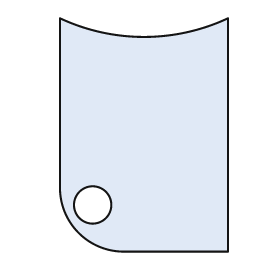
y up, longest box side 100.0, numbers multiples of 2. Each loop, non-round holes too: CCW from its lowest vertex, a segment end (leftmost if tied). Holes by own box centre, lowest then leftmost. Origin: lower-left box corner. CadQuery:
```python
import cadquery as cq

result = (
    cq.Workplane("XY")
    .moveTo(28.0, 0.0)
    .lineTo(72.0, 0.0)
    .lineTo(72.0, 100.0)
    .threePointArc((36.0, 92.0), (0.0, 100.0))
    .lineTo(0.0, 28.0)
    .threePointArc((8.0, 8.0), (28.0, 0.0))
    .close()
    .moveTo(14.0, 20.0)
    .circle(8.0)
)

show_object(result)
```